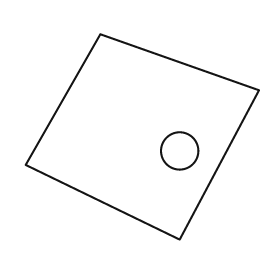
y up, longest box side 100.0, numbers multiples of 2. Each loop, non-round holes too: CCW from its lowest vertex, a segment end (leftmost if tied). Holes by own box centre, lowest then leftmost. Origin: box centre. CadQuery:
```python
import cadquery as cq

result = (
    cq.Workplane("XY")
    .moveTo(16.0, -44.0)
    .lineTo(50.0, 20.0)
    .lineTo(-18.0, 44.0)
    .lineTo(-50.0, -12.0)
    .close()
    .moveTo(16.0, -6.0)
    .circle(8.0)
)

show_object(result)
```